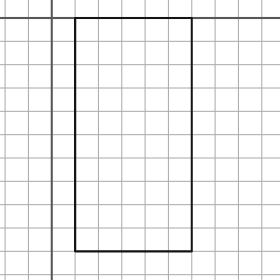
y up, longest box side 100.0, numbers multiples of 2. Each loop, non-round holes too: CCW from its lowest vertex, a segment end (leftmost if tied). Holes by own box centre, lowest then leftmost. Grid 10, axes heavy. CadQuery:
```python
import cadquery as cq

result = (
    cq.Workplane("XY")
    .moveTo(10.0, -100.0)
    .lineTo(60.0, -100.0)
    .lineTo(60.0, 0.0)
    .lineTo(10.0, 0.0)
    .close()
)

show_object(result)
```